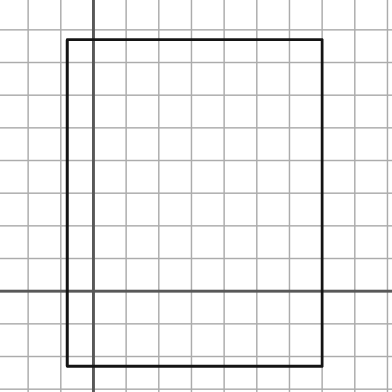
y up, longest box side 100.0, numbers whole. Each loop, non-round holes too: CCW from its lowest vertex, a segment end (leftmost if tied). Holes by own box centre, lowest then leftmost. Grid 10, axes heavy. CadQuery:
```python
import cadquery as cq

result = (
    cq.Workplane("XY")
    .moveTo(-8.0, -23.0)
    .lineTo(70.0, -23.0)
    .lineTo(70.0, 77.0)
    .lineTo(-8.0, 77.0)
    .close()
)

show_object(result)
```